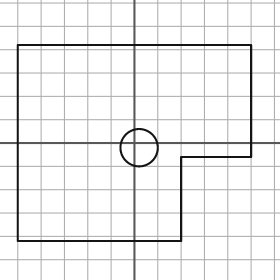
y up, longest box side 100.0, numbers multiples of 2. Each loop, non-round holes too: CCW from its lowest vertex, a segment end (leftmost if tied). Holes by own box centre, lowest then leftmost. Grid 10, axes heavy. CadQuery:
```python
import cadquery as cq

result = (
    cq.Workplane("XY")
    .moveTo(-50.0, -42.0)
    .lineTo(20.0, -42.0)
    .lineTo(20.0, -6.0)
    .lineTo(50.0, -6.0)
    .lineTo(50.0, 42.0)
    .lineTo(-50.0, 42.0)
    .close()
    .moveTo(2.0, -2.0)
    .circle(8.0)
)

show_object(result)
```